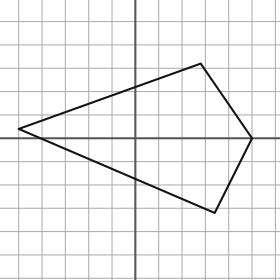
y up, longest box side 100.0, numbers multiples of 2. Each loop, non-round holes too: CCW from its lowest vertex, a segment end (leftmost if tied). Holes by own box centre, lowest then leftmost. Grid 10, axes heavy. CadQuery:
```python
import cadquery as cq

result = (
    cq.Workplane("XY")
    .moveTo(34.0, -32.0)
    .lineTo(50.0, 0.0)
    .lineTo(28.0, 32.0)
    .lineTo(-50.0, 4.0)
    .close()
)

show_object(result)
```